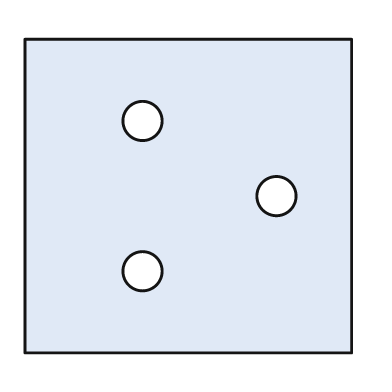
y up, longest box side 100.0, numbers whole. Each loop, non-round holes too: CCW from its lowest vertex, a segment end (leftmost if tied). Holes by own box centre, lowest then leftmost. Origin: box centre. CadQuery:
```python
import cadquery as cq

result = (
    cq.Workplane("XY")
    .moveTo(-50.0, -48.0)
    .lineTo(50.0, -48.0)
    .lineTo(50.0, 48.0)
    .lineTo(-50.0, 48.0)
    .close()
    .moveTo(-14.0, -23.0)
    .circle(6.0)
    .moveTo(27.0, 0.0)
    .circle(6.0)
    .moveTo(-14.0, 23.0)
    .circle(6.0)
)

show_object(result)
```